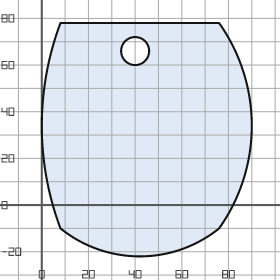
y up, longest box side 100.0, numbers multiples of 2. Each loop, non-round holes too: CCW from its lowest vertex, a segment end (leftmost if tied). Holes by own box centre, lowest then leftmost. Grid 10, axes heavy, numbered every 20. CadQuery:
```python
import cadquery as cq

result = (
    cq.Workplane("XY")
    .moveTo(8.0, -10.0)
    .threePointArc((42.0, -22.0), (76.0, -10.0))
    .threePointArc((90.0, 34.0), (76.0, 78.0))
    .lineTo(8.0, 78.0)
    .threePointArc((0.0, 34.0), (8.0, -10.0))
    .close()
    .moveTo(40.0, 66.0)
    .circle(6.0)
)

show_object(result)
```